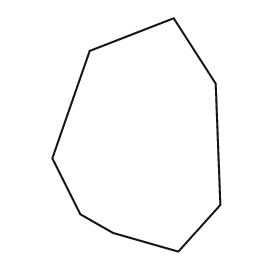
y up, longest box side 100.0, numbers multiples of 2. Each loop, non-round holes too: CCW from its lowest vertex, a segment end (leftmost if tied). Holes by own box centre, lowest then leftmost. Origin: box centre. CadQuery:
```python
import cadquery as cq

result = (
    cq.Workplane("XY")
    .moveTo(18.0, -50.0)
    .lineTo(36.0, -30.0)
    .lineTo(34.0, 22.0)
    .lineTo(16.0, 50.0)
    .lineTo(-20.0, 36.0)
    .lineTo(-36.0, -10.0)
    .lineTo(-24.0, -34.0)
    .lineTo(-10.0, -42.0)
    .close()
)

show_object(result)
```